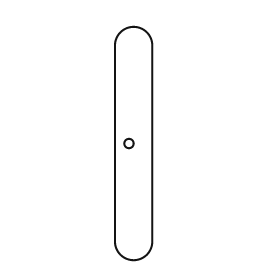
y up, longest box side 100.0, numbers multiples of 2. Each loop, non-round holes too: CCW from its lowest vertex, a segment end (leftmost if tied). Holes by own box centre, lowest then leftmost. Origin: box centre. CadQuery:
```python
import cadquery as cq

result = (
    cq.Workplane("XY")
    .moveTo(-8.0, -42.0)
    .threePointArc((0.0, -50.0), (8.0, -42.0))
    .lineTo(8.0, 42.0)
    .threePointArc((0.0, 50.0), (-8.0, 42.0))
    .close()
    .moveTo(-2.0, 0.0)
    .circle(2.0)
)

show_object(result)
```